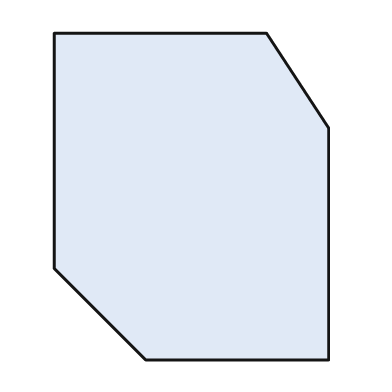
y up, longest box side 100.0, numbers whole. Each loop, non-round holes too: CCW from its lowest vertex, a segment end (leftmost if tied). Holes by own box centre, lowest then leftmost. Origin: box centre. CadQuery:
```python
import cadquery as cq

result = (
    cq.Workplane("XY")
    .moveTo(-14.0, -50.0)
    .lineTo(42.0, -50.0)
    .lineTo(42.0, 21.0)
    .lineTo(23.0, 50.0)
    .lineTo(-42.0, 50.0)
    .lineTo(-42.0, -22.0)
    .close()
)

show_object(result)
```